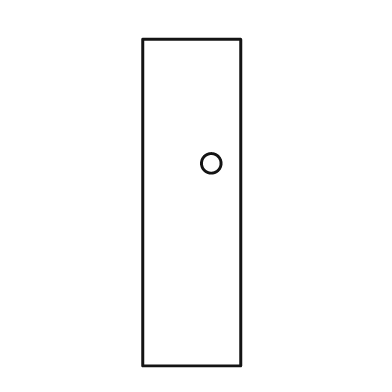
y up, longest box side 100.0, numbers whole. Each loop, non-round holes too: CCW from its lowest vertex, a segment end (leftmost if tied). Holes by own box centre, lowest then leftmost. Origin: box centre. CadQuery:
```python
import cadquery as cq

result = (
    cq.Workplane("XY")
    .moveTo(-15.0, -50.0)
    .lineTo(15.0, -50.0)
    .lineTo(15.0, 50.0)
    .lineTo(-15.0, 50.0)
    .close()
    .moveTo(6.0, 12.0)
    .circle(3.0)
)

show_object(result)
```